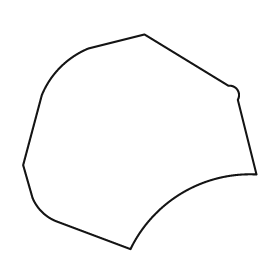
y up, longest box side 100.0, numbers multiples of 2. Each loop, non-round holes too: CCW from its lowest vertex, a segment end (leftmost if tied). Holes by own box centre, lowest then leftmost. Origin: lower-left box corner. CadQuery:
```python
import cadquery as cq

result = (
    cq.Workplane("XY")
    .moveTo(46.0, 0.0)
    .threePointArc((68.0, 24.0), (100.0, 32.0))
    .lineTo(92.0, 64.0)
    .threePointArc((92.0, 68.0), (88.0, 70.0))
    .lineTo(52.0, 92.0)
    .lineTo(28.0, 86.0)
    .threePointArc((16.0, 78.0), (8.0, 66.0))
    .lineTo(0.0, 36.0)
    .lineTo(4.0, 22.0)
    .threePointArc((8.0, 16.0), (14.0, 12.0))
    .close()
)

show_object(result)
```